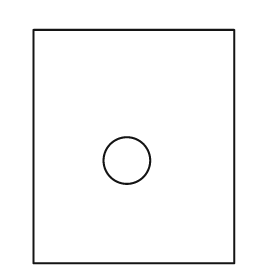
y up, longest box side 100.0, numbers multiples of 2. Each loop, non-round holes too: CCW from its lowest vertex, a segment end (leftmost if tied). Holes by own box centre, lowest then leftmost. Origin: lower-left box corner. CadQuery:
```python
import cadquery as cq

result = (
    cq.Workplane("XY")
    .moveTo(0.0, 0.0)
    .lineTo(86.0, 0.0)
    .lineTo(86.0, 100.0)
    .lineTo(0.0, 100.0)
    .close()
    .moveTo(40.0, 44.0)
    .circle(10.0)
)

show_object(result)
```